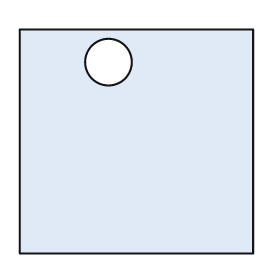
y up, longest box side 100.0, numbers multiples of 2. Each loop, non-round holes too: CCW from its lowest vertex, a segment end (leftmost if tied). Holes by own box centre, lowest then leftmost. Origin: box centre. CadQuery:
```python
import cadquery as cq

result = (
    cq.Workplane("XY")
    .moveTo(-50.0, -48.0)
    .lineTo(50.0, -48.0)
    .lineTo(50.0, 48.0)
    .lineTo(-50.0, 48.0)
    .close()
    .moveTo(-12.0, 34.0)
    .circle(10.0)
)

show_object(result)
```